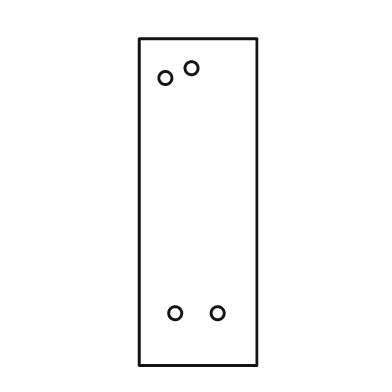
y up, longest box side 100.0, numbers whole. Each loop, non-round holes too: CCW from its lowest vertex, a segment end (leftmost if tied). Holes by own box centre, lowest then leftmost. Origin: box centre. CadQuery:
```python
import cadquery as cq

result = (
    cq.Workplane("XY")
    .moveTo(-18.0, -50.0)
    .lineTo(18.0, -50.0)
    .lineTo(18.0, 50.0)
    .lineTo(-18.0, 50.0)
    .close()
    .moveTo(-7.0, -34.0)
    .circle(2.0)
    .moveTo(6.0, -34.0)
    .circle(2.0)
    .moveTo(-10.0, 38.0)
    .circle(2.0)
    .moveTo(-2.0, 41.0)
    .circle(2.0)
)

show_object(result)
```